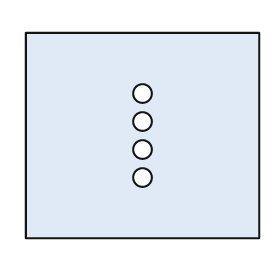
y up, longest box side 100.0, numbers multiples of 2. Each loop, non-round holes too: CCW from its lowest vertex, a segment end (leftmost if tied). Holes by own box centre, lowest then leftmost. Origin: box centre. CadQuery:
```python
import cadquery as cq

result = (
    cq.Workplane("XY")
    .moveTo(-50.0, -44.0)
    .lineTo(50.0, -44.0)
    .lineTo(50.0, 44.0)
    .lineTo(-50.0, 44.0)
    .close()
    .moveTo(0.0, -18.0)
    .circle(4.0)
    .moveTo(0.0, -6.0)
    .circle(4.0)
    .moveTo(0.0, 6.0)
    .circle(4.0)
    .moveTo(0.0, 18.0)
    .circle(4.0)
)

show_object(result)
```